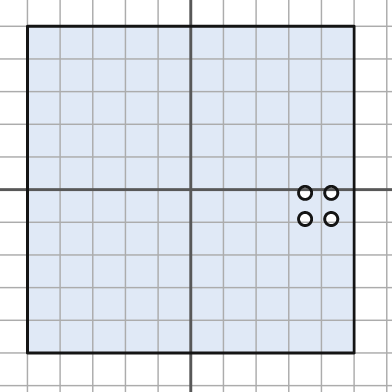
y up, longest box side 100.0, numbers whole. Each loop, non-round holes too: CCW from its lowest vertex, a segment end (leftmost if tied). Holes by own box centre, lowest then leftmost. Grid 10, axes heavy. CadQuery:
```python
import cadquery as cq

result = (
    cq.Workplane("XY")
    .moveTo(-50.0, -50.0)
    .lineTo(50.0, -50.0)
    .lineTo(50.0, 50.0)
    .lineTo(-50.0, 50.0)
    .close()
    .moveTo(35.0, -9.0)
    .circle(2.0)
    .moveTo(43.0, -9.0)
    .circle(2.0)
    .moveTo(35.0, -1.0)
    .circle(2.0)
    .moveTo(43.0, -1.0)
    .circle(2.0)
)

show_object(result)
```